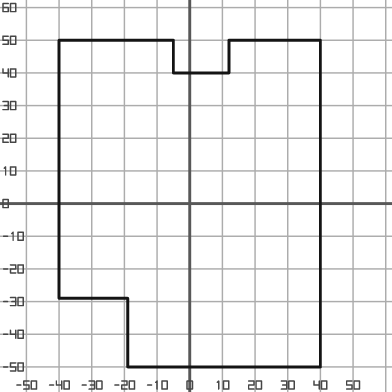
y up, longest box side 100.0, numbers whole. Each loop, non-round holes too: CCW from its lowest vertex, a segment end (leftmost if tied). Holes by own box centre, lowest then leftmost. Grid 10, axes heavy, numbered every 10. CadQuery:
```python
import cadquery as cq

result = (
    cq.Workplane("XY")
    .moveTo(-19.0, -50.0)
    .lineTo(40.0, -50.0)
    .lineTo(40.0, 50.0)
    .lineTo(12.0, 50.0)
    .lineTo(12.0, 40.0)
    .lineTo(-5.0, 40.0)
    .lineTo(-5.0, 50.0)
    .lineTo(-40.0, 50.0)
    .lineTo(-40.0, -29.0)
    .lineTo(-19.0, -29.0)
    .close()
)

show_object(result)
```